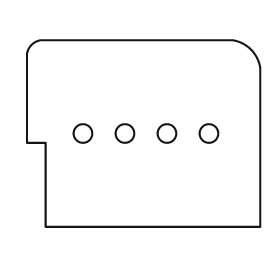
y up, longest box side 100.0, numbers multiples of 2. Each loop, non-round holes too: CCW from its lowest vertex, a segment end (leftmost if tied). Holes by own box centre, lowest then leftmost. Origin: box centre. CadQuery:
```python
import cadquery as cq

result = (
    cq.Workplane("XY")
    .moveTo(-42.0, -40.0)
    .lineTo(50.0, -40.0)
    .lineTo(50.0, 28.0)
    .threePointArc((46.0, 36.0), (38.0, 40.0))
    .lineTo(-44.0, 40.0)
    .threePointArc((-48.0, 38.0), (-50.0, 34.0))
    .lineTo(-50.0, -4.0)
    .lineTo(-42.0, -4.0)
    .close()
    .moveTo(-26.0, 0.0)
    .circle(4.0)
    .moveTo(-8.0, 0.0)
    .circle(4.0)
    .moveTo(10.0, 0.0)
    .circle(4.0)
    .moveTo(28.0, 0.0)
    .circle(4.0)
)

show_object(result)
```